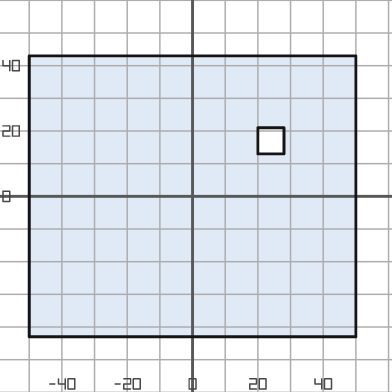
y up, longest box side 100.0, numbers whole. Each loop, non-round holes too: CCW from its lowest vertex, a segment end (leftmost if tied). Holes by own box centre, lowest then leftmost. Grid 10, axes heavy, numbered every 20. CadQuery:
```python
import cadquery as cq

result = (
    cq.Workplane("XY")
    .moveTo(-50.0, -43.0)
    .lineTo(50.0, -43.0)
    .lineTo(50.0, 43.0)
    .lineTo(-50.0, 43.0)
    .close()
    .moveTo(20.0, 13.0)
    .lineTo(28.0, 13.0)
    .lineTo(28.0, 21.0)
    .lineTo(20.0, 21.0)
    .close()
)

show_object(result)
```